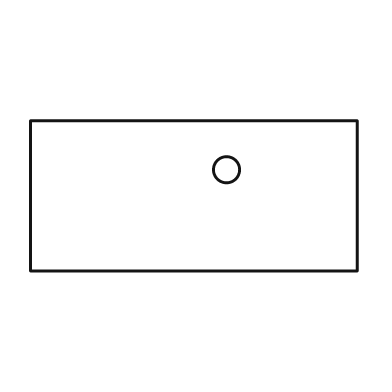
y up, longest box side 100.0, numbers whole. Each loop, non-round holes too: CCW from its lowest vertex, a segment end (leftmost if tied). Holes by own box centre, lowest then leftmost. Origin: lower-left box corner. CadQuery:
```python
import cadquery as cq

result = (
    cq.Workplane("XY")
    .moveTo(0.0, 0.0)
    .lineTo(100.0, 0.0)
    .lineTo(100.0, 46.0)
    .lineTo(0.0, 46.0)
    .close()
    .moveTo(60.0, 31.0)
    .circle(4.0)
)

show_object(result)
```